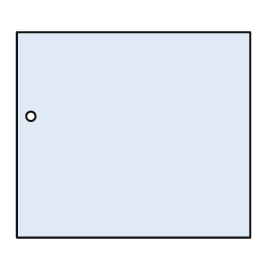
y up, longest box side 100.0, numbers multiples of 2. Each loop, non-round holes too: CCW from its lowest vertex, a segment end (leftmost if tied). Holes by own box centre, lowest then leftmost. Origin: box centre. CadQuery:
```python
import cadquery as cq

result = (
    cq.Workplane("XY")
    .moveTo(-50.0, -44.0)
    .lineTo(50.0, -44.0)
    .lineTo(50.0, 44.0)
    .lineTo(-50.0, 44.0)
    .close()
    .moveTo(-44.0, 8.0)
    .circle(2.0)
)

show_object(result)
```